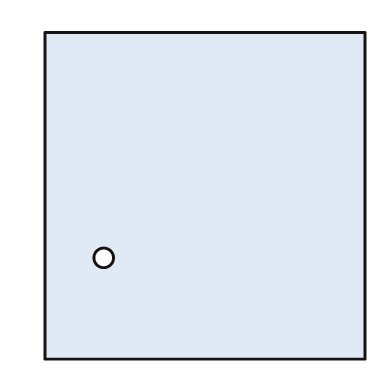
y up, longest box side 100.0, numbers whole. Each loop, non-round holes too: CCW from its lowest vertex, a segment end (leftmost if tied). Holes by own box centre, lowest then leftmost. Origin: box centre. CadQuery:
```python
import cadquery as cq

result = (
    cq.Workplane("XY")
    .moveTo(-49.0, -50.0)
    .lineTo(49.0, -50.0)
    .lineTo(49.0, 50.0)
    .lineTo(-49.0, 50.0)
    .close()
    .moveTo(-31.0, -19.0)
    .circle(3.0)
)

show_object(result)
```